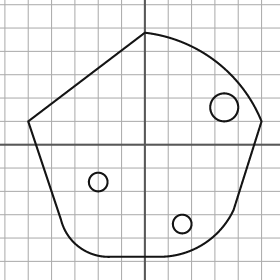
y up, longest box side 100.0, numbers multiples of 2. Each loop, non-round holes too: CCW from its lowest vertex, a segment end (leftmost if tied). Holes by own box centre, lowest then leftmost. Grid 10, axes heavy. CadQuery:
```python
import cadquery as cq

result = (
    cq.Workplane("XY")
    .moveTo(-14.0, -48.0)
    .lineTo(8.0, -48.0)
    .threePointArc((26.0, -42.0), (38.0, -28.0))
    .lineTo(50.0, 10.0)
    .threePointArc((30.0, 36.0), (0.0, 48.0))
    .lineTo(-50.0, 10.0)
    .lineTo(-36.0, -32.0)
    .threePointArc((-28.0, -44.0), (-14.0, -48.0))
    .close()
    .moveTo(16.0, -34.0)
    .circle(4.0)
    .moveTo(-20.0, -16.0)
    .circle(4.0)
    .moveTo(34.0, 16.0)
    .circle(6.0)
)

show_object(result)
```